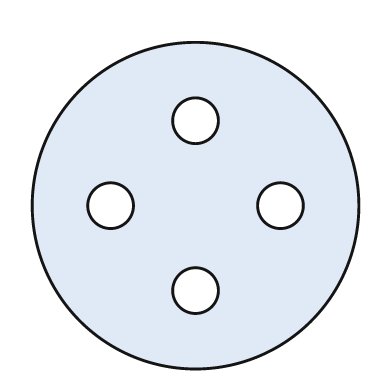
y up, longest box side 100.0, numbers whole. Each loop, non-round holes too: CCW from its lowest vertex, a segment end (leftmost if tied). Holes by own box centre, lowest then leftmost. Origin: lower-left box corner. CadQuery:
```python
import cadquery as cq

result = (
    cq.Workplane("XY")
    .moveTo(50.0, 50.0)
    .circle(50.0)
    .moveTo(50.0, 24.0)
    .circle(7.0)
    .moveTo(24.0, 50.0)
    .circle(7.0)
    .moveTo(76.0, 50.0)
    .circle(7.0)
    .moveTo(50.0, 76.0)
    .circle(7.0)
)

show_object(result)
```